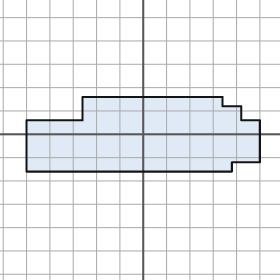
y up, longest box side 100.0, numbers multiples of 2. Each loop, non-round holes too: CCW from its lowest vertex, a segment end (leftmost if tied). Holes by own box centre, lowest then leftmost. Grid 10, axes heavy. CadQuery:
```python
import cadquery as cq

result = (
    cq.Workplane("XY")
    .moveTo(-50.0, -16.0)
    .lineTo(38.0, -16.0)
    .lineTo(38.0, -12.0)
    .lineTo(50.0, -12.0)
    .lineTo(50.0, 6.0)
    .lineTo(42.0, 6.0)
    .lineTo(42.0, 12.0)
    .lineTo(34.0, 12.0)
    .lineTo(34.0, 16.0)
    .lineTo(-26.0, 16.0)
    .lineTo(-26.0, 6.0)
    .lineTo(-50.0, 6.0)
    .close()
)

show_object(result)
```